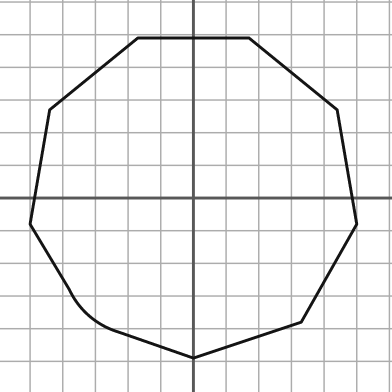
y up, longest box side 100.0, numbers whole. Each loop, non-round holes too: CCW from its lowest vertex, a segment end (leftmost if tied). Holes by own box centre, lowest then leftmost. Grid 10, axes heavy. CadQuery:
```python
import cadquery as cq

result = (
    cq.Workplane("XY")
    .moveTo(0.0, -49.0)
    .lineTo(33.0, -38.0)
    .lineTo(50.0, -8.0)
    .lineTo(44.0, 27.0)
    .lineTo(17.0, 49.0)
    .lineTo(-17.0, 49.0)
    .lineTo(-44.0, 27.0)
    .lineTo(-50.0, -8.0)
    .lineTo(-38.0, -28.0)
    .threePointArc((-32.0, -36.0), (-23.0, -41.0))
    .close()
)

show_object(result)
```